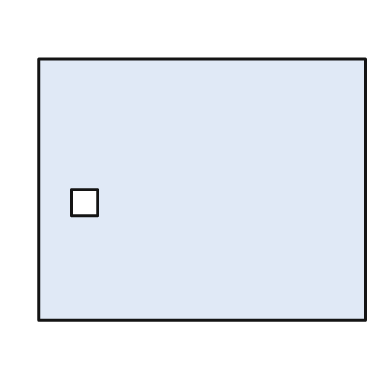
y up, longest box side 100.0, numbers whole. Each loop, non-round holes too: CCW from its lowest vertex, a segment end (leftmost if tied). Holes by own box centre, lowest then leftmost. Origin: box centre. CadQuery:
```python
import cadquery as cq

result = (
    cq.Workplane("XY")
    .moveTo(-50.0, -40.0)
    .lineTo(50.0, -40.0)
    .lineTo(50.0, 40.0)
    .lineTo(-50.0, 40.0)
    .close()
    .moveTo(-40.0, -8.0)
    .lineTo(-32.0, -8.0)
    .lineTo(-32.0, 0.0)
    .lineTo(-40.0, 0.0)
    .close()
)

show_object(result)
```